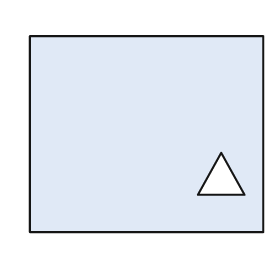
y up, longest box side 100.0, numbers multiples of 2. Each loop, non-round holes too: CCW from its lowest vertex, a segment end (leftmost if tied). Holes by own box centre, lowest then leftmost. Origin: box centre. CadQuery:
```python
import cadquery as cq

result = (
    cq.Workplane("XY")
    .moveTo(-50.0, -42.0)
    .lineTo(50.0, -42.0)
    .lineTo(50.0, 42.0)
    .lineTo(-50.0, 42.0)
    .close()
    .moveTo(22.0, -26.0)
    .lineTo(42.0, -26.0)
    .lineTo(32.0, -8.0)
    .close()
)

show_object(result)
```